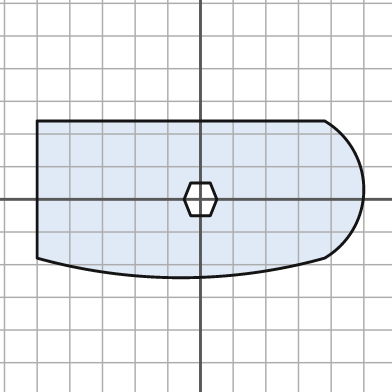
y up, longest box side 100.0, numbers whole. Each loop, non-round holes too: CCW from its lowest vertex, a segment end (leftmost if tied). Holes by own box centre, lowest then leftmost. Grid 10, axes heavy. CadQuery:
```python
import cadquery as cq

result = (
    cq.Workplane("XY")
    .moveTo(-50.0, -18.0)
    .threePointArc((-6.0, -24.0), (38.0, -18.0))
    .threePointArc((50.0, 3.0), (38.0, 24.0))
    .lineTo(-50.0, 24.0)
    .close()
    .moveTo(-3.0, -5.0)
    .lineTo(3.0, -5.0)
    .lineTo(5.0, 0.0)
    .lineTo(3.0, 5.0)
    .lineTo(-3.0, 5.0)
    .lineTo(-5.0, 0.0)
    .close()
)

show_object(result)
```